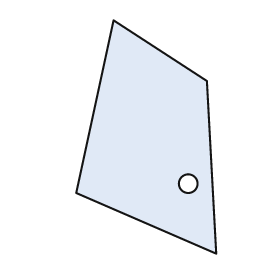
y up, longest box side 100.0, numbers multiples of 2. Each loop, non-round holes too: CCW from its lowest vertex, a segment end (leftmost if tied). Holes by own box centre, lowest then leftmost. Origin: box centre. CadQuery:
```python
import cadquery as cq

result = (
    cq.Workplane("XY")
    .moveTo(30.0, -50.0)
    .lineTo(26.0, 24.0)
    .lineTo(-14.0, 50.0)
    .lineTo(-30.0, -24.0)
    .close()
    .moveTo(18.0, -20.0)
    .circle(4.0)
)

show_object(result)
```